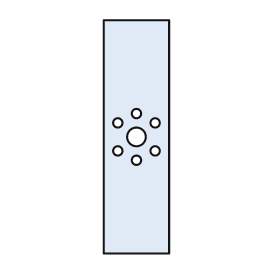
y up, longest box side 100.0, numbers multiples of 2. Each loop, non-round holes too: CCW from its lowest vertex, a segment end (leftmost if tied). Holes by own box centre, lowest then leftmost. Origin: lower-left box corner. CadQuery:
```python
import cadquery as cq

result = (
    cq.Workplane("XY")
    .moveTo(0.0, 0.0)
    .lineTo(28.0, 0.0)
    .lineTo(28.0, 100.0)
    .lineTo(0.0, 100.0)
    .close()
    .moveTo(14.0, 40.0)
    .circle(2.0)
    .moveTo(6.0, 44.0)
    .circle(2.0)
    .moveTo(22.0, 44.0)
    .circle(2.0)
    .moveTo(14.0, 50.0)
    .circle(4.0)
    .moveTo(6.0, 56.0)
    .circle(2.0)
    .moveTo(22.0, 56.0)
    .circle(2.0)
    .moveTo(14.0, 60.0)
    .circle(2.0)
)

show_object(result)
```